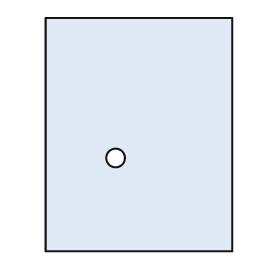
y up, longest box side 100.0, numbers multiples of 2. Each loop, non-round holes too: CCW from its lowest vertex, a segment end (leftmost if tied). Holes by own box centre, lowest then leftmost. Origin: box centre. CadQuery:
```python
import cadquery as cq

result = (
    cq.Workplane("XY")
    .moveTo(-40.0, -50.0)
    .lineTo(40.0, -50.0)
    .lineTo(40.0, 50.0)
    .lineTo(-40.0, 50.0)
    .close()
    .moveTo(-10.0, -10.0)
    .circle(4.0)
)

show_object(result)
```